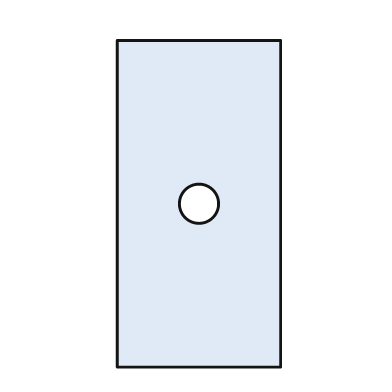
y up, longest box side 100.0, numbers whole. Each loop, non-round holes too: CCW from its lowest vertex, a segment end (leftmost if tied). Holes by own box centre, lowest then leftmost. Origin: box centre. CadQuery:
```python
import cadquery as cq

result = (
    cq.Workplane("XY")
    .moveTo(-25.0, -50.0)
    .lineTo(25.0, -50.0)
    .lineTo(25.0, 50.0)
    .lineTo(-25.0, 50.0)
    .close()
    .moveTo(0.0, 0.0)
    .circle(6.0)
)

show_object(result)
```